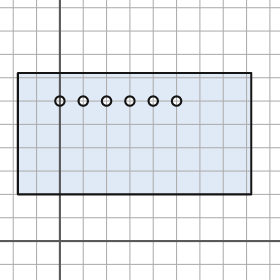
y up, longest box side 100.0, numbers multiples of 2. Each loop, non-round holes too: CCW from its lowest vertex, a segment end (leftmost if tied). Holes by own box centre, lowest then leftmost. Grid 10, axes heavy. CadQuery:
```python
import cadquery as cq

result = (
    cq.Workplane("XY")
    .moveTo(-18.0, 20.0)
    .lineTo(82.0, 20.0)
    .lineTo(82.0, 72.0)
    .lineTo(-18.0, 72.0)
    .close()
    .moveTo(0.0, 60.0)
    .circle(2.0)
    .moveTo(10.0, 60.0)
    .circle(2.0)
    .moveTo(20.0, 60.0)
    .circle(2.0)
    .moveTo(30.0, 60.0)
    .circle(2.0)
    .moveTo(40.0, 60.0)
    .circle(2.0)
    .moveTo(50.0, 60.0)
    .circle(2.0)
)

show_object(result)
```